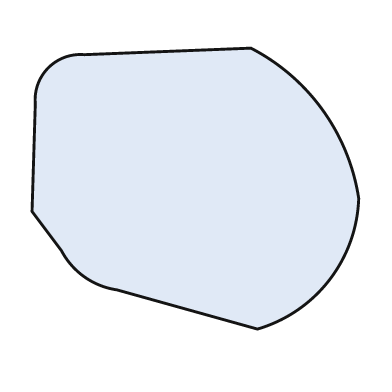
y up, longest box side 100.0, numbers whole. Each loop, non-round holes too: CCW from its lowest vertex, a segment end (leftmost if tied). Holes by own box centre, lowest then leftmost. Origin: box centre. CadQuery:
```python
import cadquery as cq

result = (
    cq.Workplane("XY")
    .moveTo(19.0, -43.0)
    .threePointArc((41.0, -28.0), (50.0, -3.0))
    .threePointArc((39.0, 24.0), (17.0, 43.0))
    .lineTo(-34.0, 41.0)
    .threePointArc((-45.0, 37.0), (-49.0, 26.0))
    .lineTo(-50.0, -7.0)
    .lineTo(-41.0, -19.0)
    .threePointArc((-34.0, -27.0), (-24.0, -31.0))
    .close()
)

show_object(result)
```